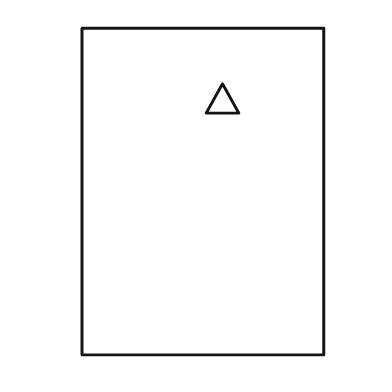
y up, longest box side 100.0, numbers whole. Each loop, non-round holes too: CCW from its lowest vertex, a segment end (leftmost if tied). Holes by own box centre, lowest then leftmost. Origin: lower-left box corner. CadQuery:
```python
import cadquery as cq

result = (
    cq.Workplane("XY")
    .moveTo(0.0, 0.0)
    .lineTo(74.0, 0.0)
    .lineTo(74.0, 100.0)
    .lineTo(0.0, 100.0)
    .close()
    .moveTo(38.0, 74.0)
    .lineTo(48.0, 74.0)
    .lineTo(43.0, 83.0)
    .close()
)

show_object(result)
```